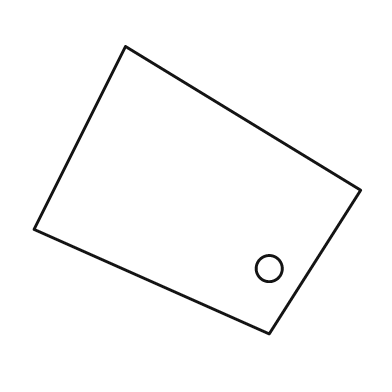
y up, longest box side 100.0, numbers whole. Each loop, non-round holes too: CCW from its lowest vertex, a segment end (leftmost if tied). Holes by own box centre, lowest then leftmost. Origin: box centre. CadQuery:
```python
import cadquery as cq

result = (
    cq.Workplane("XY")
    .moveTo(22.0, -44.0)
    .lineTo(50.0, 0.0)
    .lineTo(-22.0, 44.0)
    .lineTo(-50.0, -12.0)
    .close()
    .moveTo(22.0, -24.0)
    .circle(4.0)
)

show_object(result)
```